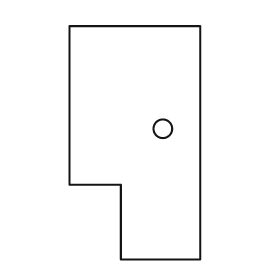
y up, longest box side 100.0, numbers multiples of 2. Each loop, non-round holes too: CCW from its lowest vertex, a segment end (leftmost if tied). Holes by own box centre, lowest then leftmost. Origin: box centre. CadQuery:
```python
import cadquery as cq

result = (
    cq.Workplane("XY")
    .moveTo(-6.0, -50.0)
    .lineTo(28.0, -50.0)
    .lineTo(28.0, 50.0)
    .lineTo(-28.0, 50.0)
    .lineTo(-28.0, -18.0)
    .lineTo(-6.0, -18.0)
    .close()
    .moveTo(12.0, 6.0)
    .circle(4.0)
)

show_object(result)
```